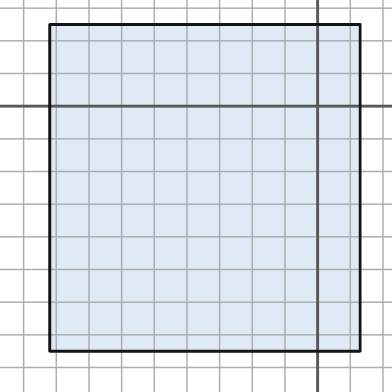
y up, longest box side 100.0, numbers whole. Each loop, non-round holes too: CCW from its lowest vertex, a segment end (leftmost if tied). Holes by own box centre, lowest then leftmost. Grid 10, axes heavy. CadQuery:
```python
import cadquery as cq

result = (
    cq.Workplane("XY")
    .moveTo(-82.0, -75.0)
    .lineTo(13.0, -75.0)
    .lineTo(13.0, 25.0)
    .lineTo(-82.0, 25.0)
    .close()
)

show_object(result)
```